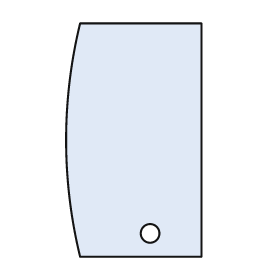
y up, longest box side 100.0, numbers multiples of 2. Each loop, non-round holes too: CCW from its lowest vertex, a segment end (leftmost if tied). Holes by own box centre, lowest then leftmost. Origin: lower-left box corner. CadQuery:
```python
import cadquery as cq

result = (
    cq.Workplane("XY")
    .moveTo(6.0, 0.0)
    .lineTo(58.0, 0.0)
    .lineTo(58.0, 100.0)
    .lineTo(6.0, 100.0)
    .threePointArc((0.0, 50.0), (6.0, 0.0))
    .close()
    .moveTo(36.0, 10.0)
    .circle(4.0)
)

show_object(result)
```